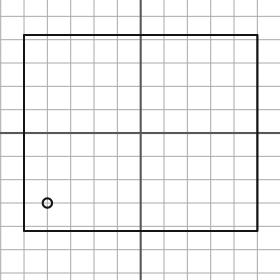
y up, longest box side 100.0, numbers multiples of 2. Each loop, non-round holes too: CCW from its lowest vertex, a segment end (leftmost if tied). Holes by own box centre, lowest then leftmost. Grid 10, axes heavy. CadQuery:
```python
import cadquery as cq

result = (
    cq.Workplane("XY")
    .moveTo(-50.0, -42.0)
    .lineTo(50.0, -42.0)
    .lineTo(50.0, 42.0)
    .lineTo(-50.0, 42.0)
    .close()
    .moveTo(-40.0, -30.0)
    .circle(2.0)
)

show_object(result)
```